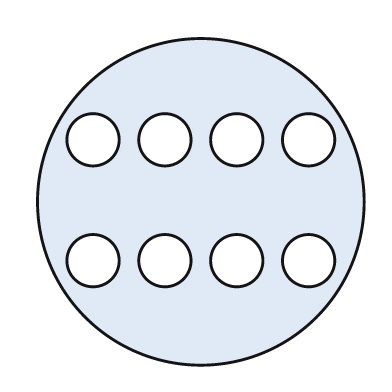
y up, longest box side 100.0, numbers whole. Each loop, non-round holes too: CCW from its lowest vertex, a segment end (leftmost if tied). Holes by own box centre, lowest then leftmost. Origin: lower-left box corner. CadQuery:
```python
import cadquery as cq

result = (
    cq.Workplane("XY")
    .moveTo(50.0, 50.0)
    .circle(50.0)
    .moveTo(17.0, 32.0)
    .circle(8.0)
    .moveTo(39.0, 32.0)
    .circle(8.0)
    .moveTo(61.0, 32.0)
    .circle(8.0)
    .moveTo(83.0, 32.0)
    .circle(8.0)
    .moveTo(17.0, 69.0)
    .circle(8.0)
    .moveTo(39.0, 69.0)
    .circle(8.0)
    .moveTo(61.0, 69.0)
    .circle(8.0)
    .moveTo(83.0, 69.0)
    .circle(8.0)
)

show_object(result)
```